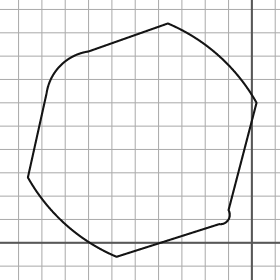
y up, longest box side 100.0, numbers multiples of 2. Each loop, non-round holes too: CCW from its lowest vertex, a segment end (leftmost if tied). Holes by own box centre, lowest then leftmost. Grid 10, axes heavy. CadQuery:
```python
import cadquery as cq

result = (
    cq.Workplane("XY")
    .moveTo(-58.0, -6.0)
    .lineTo(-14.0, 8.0)
    .threePointArc((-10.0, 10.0), (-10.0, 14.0))
    .lineTo(2.0, 60.0)
    .threePointArc((-14.0, 80.0), (-36.0, 94.0))
    .lineTo(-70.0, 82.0)
    .threePointArc((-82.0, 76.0), (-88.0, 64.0))
    .lineTo(-96.0, 28.0)
    .threePointArc((-80.0, 8.0), (-58.0, -6.0))
    .close()
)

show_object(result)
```